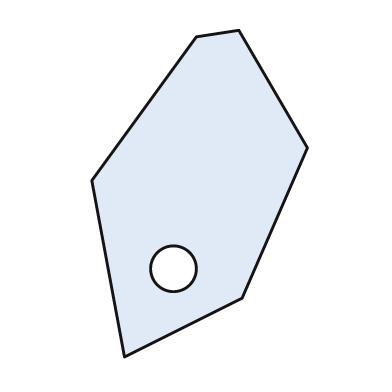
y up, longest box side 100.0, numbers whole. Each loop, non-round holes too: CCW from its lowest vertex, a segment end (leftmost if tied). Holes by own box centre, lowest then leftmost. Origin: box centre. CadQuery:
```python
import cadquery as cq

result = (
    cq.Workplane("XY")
    .moveTo(-23.0, -50.0)
    .lineTo(13.0, -32.0)
    .lineTo(33.0, 14.0)
    .lineTo(12.0, 50.0)
    .lineTo(-1.0, 48.0)
    .lineTo(-33.0, 4.0)
    .close()
    .moveTo(-8.0, -23.0)
    .circle(7.0)
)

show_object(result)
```